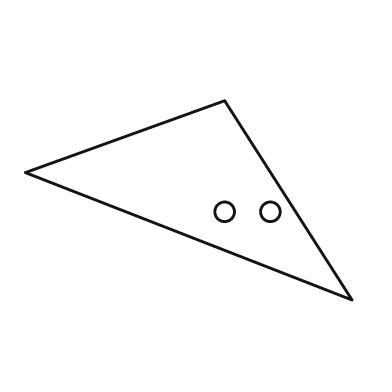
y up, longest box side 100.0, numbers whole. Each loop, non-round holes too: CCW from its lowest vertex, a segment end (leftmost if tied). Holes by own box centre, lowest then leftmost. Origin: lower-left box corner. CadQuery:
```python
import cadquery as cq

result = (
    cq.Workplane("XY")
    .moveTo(100.0, 0.0)
    .lineTo(61.0, 61.0)
    .lineTo(0.0, 39.0)
    .close()
    .moveTo(61.0, 27.0)
    .circle(3.0)
    .moveTo(75.0, 27.0)
    .circle(3.0)
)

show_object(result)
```